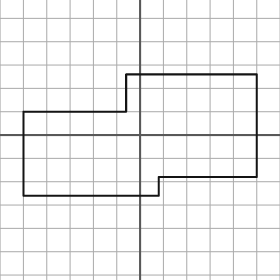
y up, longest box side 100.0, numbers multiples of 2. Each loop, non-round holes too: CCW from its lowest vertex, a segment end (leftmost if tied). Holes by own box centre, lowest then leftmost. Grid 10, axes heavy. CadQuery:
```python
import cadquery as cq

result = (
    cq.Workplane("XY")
    .moveTo(-50.0, -26.0)
    .lineTo(8.0, -26.0)
    .lineTo(8.0, -18.0)
    .lineTo(50.0, -18.0)
    .lineTo(50.0, 26.0)
    .lineTo(-6.0, 26.0)
    .lineTo(-6.0, 10.0)
    .lineTo(-50.0, 10.0)
    .close()
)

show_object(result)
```